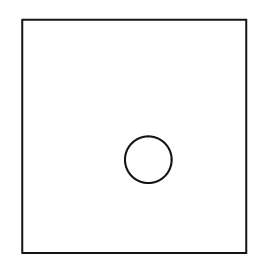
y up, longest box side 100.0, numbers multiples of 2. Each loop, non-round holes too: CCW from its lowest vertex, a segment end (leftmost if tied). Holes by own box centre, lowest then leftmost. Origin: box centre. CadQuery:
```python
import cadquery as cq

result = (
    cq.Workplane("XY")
    .moveTo(-48.0, -50.0)
    .lineTo(48.0, -50.0)
    .lineTo(48.0, 50.0)
    .lineTo(-48.0, 50.0)
    .close()
    .moveTo(6.0, -10.0)
    .circle(10.0)
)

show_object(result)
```